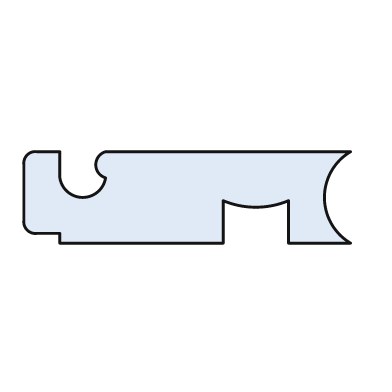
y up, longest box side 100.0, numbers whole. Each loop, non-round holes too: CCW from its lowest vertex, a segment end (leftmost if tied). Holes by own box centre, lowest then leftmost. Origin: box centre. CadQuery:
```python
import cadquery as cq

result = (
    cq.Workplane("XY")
    .moveTo(-39.0, -14.0)
    .lineTo(11.0, -14.0)
    .lineTo(11.0, -1.0)
    .threePointArc((21.0, -3.0), (31.0, -1.0))
    .lineTo(31.0, -14.0)
    .lineTo(50.0, -14.0)
    .threePointArc((42.0, 0.0), (50.0, 14.0))
    .lineTo(-25.0, 14.0)
    .threePointArc((-28.0, 10.0), (-25.0, 6.0))
    .threePointArc((-32.0, 0.0), (-39.0, 6.0))
    .lineTo(-39.0, 14.0)
    .lineTo(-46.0, 14.0)
    .threePointArc((-49.0, 13.0), (-50.0, 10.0))
    .lineTo(-50.0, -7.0)
    .threePointArc((-49.0, -10.0), (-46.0, -11.0))
    .lineTo(-39.0, -11.0)
    .close()
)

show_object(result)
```